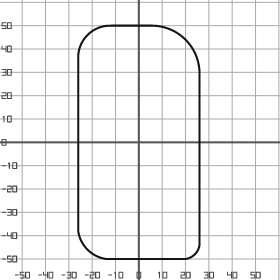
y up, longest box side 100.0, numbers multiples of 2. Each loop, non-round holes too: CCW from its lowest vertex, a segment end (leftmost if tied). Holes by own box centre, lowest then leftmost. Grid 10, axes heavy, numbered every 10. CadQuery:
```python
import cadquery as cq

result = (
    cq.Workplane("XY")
    .moveTo(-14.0, -50.0)
    .lineTo(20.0, -50.0)
    .threePointArc((24.0, -48.0), (26.0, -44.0))
    .lineTo(26.0, 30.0)
    .threePointArc((20.0, 44.0), (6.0, 50.0))
    .lineTo(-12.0, 50.0)
    .threePointArc((-22.0, 46.0), (-26.0, 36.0))
    .lineTo(-26.0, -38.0)
    .threePointArc((-22.0, -46.0), (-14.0, -50.0))
    .close()
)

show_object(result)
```